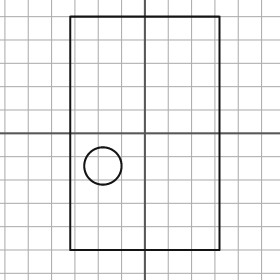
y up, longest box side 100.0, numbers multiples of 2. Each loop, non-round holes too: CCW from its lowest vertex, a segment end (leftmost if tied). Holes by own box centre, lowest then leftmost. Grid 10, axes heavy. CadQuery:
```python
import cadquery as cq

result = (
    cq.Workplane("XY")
    .moveTo(-32.0, -50.0)
    .lineTo(32.0, -50.0)
    .lineTo(32.0, 50.0)
    .lineTo(-32.0, 50.0)
    .close()
    .moveTo(-18.0, -14.0)
    .circle(8.0)
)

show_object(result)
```